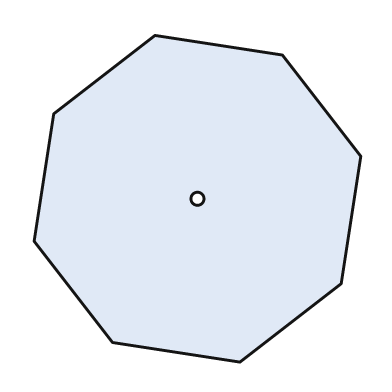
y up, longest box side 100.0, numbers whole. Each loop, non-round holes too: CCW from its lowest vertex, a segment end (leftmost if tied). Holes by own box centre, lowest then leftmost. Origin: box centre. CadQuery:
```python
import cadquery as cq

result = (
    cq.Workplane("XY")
    .moveTo(13.0, -50.0)
    .lineTo(44.0, -26.0)
    .lineTo(50.0, 13.0)
    .lineTo(26.0, 44.0)
    .lineTo(-13.0, 50.0)
    .lineTo(-44.0, 26.0)
    .lineTo(-50.0, -13.0)
    .lineTo(-26.0, -44.0)
    .close()
    .moveTo(0.0, 0.0)
    .circle(2.0)
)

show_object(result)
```